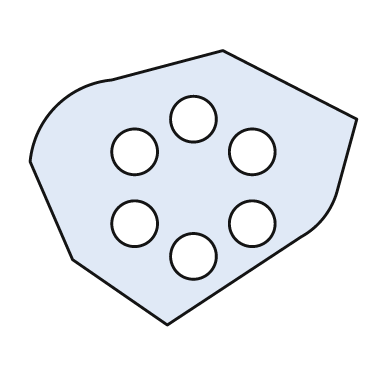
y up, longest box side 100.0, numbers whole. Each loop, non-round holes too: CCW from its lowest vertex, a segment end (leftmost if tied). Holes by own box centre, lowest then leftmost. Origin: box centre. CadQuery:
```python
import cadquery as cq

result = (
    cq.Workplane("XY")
    .moveTo(-8.0, -42.0)
    .lineTo(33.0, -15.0)
    .threePointArc((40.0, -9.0), (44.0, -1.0))
    .lineTo(50.0, 21.0)
    .lineTo(9.0, 42.0)
    .lineTo(-25.0, 33.0)
    .threePointArc((-42.0, 25.0), (-50.0, 8.0))
    .lineTo(-37.0, -22.0)
    .close()
    .moveTo(0.0, -21.0)
    .circle(7.0)
    .moveTo(-18.0, -11.0)
    .circle(7.0)
    .moveTo(18.0, -11.0)
    .circle(7.0)
    .moveTo(-18.0, 11.0)
    .circle(7.0)
    .moveTo(18.0, 11.0)
    .circle(7.0)
    .moveTo(0.0, 21.0)
    .circle(7.0)
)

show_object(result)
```